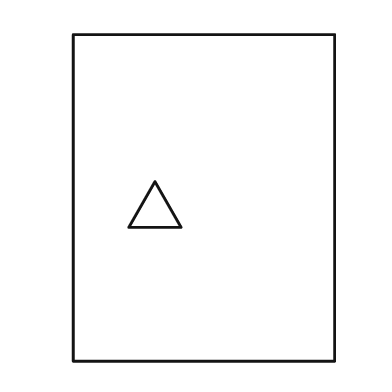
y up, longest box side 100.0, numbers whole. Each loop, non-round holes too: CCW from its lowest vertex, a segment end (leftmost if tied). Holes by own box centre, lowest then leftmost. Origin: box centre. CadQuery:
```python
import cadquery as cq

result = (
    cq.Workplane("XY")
    .moveTo(-40.0, -50.0)
    .lineTo(40.0, -50.0)
    .lineTo(40.0, 50.0)
    .lineTo(-40.0, 50.0)
    .close()
    .moveTo(-23.0, -9.0)
    .lineTo(-7.0, -9.0)
    .lineTo(-15.0, 5.0)
    .close()
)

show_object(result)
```